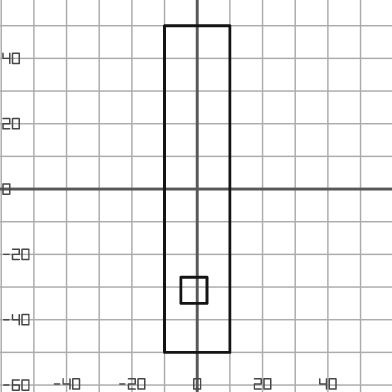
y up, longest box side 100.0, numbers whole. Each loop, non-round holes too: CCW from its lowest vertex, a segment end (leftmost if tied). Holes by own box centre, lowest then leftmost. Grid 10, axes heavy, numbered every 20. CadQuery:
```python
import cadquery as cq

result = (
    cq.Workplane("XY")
    .moveTo(-10.0, -50.0)
    .lineTo(10.0, -50.0)
    .lineTo(10.0, 50.0)
    .lineTo(-10.0, 50.0)
    .close()
    .moveTo(-5.0, -35.0)
    .lineTo(3.0, -35.0)
    .lineTo(3.0, -27.0)
    .lineTo(-5.0, -27.0)
    .close()
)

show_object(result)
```